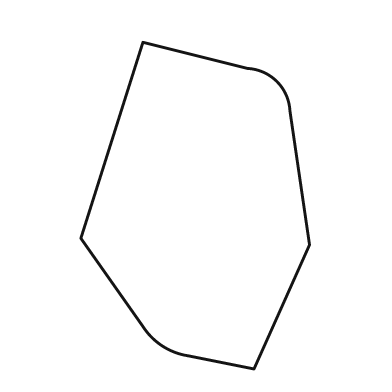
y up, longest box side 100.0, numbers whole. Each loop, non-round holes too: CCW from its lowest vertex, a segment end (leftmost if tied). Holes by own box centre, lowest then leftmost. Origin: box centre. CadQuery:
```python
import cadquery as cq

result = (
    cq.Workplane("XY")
    .moveTo(18.0, -50.0)
    .lineTo(35.0, -12.0)
    .lineTo(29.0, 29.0)
    .threePointArc((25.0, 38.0), (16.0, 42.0))
    .lineTo(-16.0, 50.0)
    .lineTo(-35.0, -10.0)
    .lineTo(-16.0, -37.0)
    .threePointArc((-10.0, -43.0), (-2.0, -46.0))
    .close()
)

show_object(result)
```